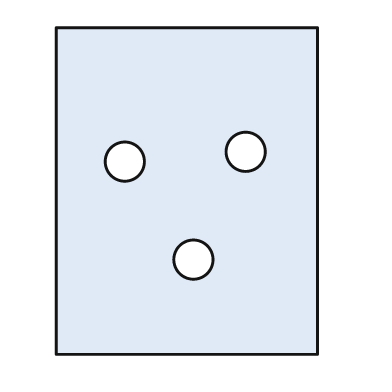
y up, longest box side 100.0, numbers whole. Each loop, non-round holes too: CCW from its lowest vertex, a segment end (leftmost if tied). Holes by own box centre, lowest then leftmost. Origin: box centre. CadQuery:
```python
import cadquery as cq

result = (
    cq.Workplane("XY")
    .moveTo(-40.0, -50.0)
    .lineTo(40.0, -50.0)
    .lineTo(40.0, 50.0)
    .lineTo(-40.0, 50.0)
    .close()
    .moveTo(2.0, -21.0)
    .circle(6.0)
    .moveTo(-19.0, 9.0)
    .circle(6.0)
    .moveTo(18.0, 12.0)
    .circle(6.0)
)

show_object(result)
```